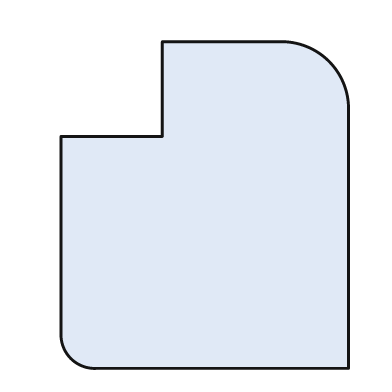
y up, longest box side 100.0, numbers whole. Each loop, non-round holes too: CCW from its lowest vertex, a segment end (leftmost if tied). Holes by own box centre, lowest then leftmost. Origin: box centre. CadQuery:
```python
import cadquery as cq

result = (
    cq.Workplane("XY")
    .moveTo(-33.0, -50.0)
    .lineTo(44.0, -50.0)
    .lineTo(44.0, 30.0)
    .threePointArc((38.0, 44.0), (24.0, 50.0))
    .lineTo(-13.0, 50.0)
    .lineTo(-13.0, 21.0)
    .lineTo(-44.0, 21.0)
    .lineTo(-44.0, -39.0)
    .threePointArc((-41.0, -47.0), (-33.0, -50.0))
    .close()
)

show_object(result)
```